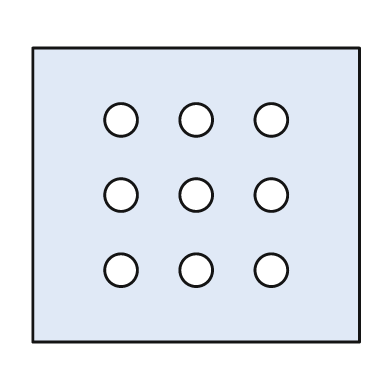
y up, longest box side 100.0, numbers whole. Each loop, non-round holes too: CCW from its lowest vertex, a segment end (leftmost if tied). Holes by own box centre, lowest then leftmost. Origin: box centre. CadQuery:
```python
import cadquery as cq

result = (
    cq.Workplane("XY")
    .moveTo(-50.0, -45.0)
    .lineTo(50.0, -45.0)
    .lineTo(50.0, 45.0)
    .lineTo(-50.0, 45.0)
    .close()
    .moveTo(-23.0, -23.0)
    .circle(5.0)
    .moveTo(0.0, -23.0)
    .circle(5.0)
    .moveTo(23.0, -23.0)
    .circle(5.0)
    .moveTo(-23.0, 0.0)
    .circle(5.0)
    .moveTo(0.0, 0.0)
    .circle(5.0)
    .moveTo(23.0, 0.0)
    .circle(5.0)
    .moveTo(-23.0, 23.0)
    .circle(5.0)
    .moveTo(0.0, 23.0)
    .circle(5.0)
    .moveTo(23.0, 23.0)
    .circle(5.0)
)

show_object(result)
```